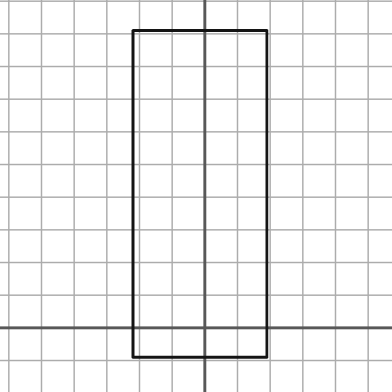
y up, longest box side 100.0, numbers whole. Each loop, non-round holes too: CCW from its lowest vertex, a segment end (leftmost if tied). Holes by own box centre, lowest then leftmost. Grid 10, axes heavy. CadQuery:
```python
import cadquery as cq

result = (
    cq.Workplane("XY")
    .moveTo(-22.0, -9.0)
    .lineTo(19.0, -9.0)
    .lineTo(19.0, 91.0)
    .lineTo(-22.0, 91.0)
    .close()
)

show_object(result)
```